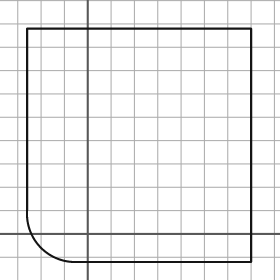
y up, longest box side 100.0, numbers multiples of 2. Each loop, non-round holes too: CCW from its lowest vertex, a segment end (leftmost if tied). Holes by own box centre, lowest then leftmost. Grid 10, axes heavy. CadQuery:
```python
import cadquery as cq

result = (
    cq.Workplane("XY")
    .moveTo(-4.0, -12.0)
    .lineTo(70.0, -12.0)
    .lineTo(70.0, 88.0)
    .lineTo(-26.0, 88.0)
    .lineTo(-26.0, 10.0)
    .threePointArc((-20.0, -6.0), (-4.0, -12.0))
    .close()
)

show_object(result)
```